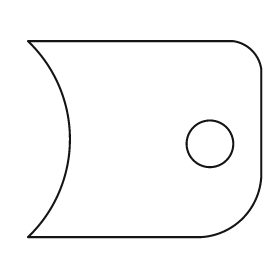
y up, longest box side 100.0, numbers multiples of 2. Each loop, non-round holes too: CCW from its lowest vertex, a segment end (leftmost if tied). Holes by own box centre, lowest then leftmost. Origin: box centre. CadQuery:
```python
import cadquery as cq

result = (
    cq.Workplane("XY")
    .moveTo(-50.0, -42.0)
    .lineTo(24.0, -42.0)
    .threePointArc((42.0, -34.0), (50.0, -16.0))
    .lineTo(50.0, 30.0)
    .threePointArc((46.0, 38.0), (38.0, 42.0))
    .lineTo(-50.0, 42.0)
    .threePointArc((-32.0, 0.0), (-50.0, -42.0))
    .close()
    .moveTo(28.0, -2.0)
    .circle(10.0)
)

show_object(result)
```